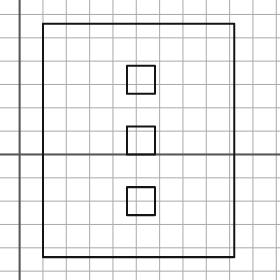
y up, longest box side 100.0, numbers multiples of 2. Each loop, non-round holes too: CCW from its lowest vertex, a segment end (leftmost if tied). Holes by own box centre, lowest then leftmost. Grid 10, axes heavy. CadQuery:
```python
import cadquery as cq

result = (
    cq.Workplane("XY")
    .moveTo(10.0, -44.0)
    .lineTo(92.0, -44.0)
    .lineTo(92.0, 56.0)
    .lineTo(10.0, 56.0)
    .close()
    .moveTo(46.0, -26.0)
    .lineTo(58.0, -26.0)
    .lineTo(58.0, -14.0)
    .lineTo(46.0, -14.0)
    .close()
    .moveTo(46.0, 0.0)
    .lineTo(58.0, 0.0)
    .lineTo(58.0, 12.0)
    .lineTo(46.0, 12.0)
    .close()
    .moveTo(46.0, 26.0)
    .lineTo(58.0, 26.0)
    .lineTo(58.0, 38.0)
    .lineTo(46.0, 38.0)
    .close()
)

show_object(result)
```